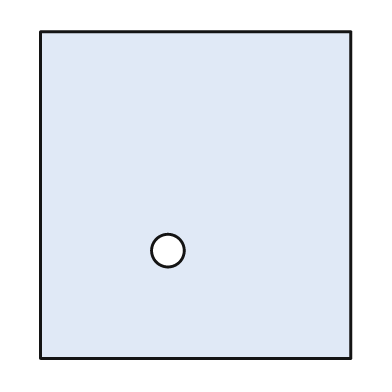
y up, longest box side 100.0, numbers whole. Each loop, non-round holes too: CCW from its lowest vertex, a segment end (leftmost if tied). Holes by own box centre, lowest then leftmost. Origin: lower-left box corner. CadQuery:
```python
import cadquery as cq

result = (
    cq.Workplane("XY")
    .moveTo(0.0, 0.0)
    .lineTo(95.0, 0.0)
    .lineTo(95.0, 100.0)
    .lineTo(0.0, 100.0)
    .close()
    .moveTo(39.0, 33.0)
    .circle(5.0)
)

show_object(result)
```